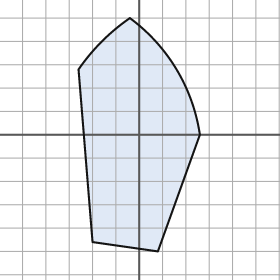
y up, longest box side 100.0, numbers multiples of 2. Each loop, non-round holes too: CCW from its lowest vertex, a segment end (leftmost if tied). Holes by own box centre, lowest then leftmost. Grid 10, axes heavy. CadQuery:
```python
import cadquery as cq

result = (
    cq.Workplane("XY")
    .moveTo(8.0, -50.0)
    .lineTo(26.0, 0.0)
    .threePointArc((16.0, 28.0), (-4.0, 50.0))
    .threePointArc((-16.0, 40.0), (-26.0, 28.0))
    .lineTo(-20.0, -46.0)
    .close()
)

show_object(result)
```